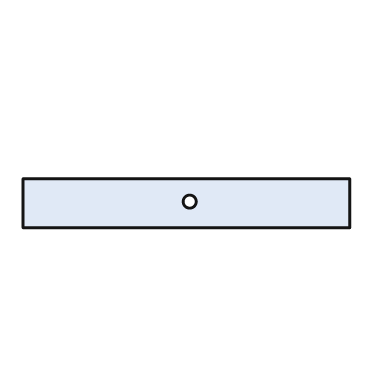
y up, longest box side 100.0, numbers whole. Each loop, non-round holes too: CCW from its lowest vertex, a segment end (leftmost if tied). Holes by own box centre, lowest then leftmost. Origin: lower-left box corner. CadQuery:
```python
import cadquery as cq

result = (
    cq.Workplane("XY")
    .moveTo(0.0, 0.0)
    .lineTo(100.0, 0.0)
    .lineTo(100.0, 15.0)
    .lineTo(0.0, 15.0)
    .close()
    .moveTo(51.0, 8.0)
    .circle(2.0)
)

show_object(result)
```